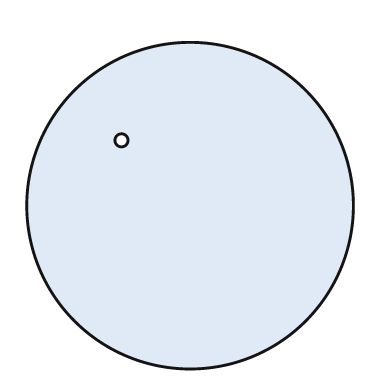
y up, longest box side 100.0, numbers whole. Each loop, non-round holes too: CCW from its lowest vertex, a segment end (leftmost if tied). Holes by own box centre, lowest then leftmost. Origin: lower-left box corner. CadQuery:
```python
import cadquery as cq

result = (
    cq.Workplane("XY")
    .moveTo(50.0, 50.0)
    .circle(50.0)
    .moveTo(29.0, 70.0)
    .circle(2.0)
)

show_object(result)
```